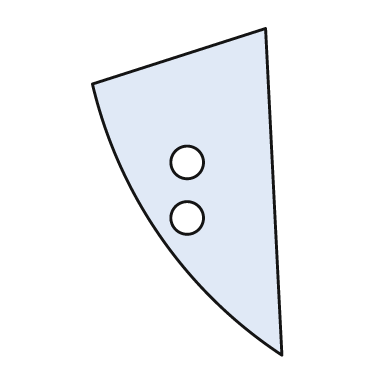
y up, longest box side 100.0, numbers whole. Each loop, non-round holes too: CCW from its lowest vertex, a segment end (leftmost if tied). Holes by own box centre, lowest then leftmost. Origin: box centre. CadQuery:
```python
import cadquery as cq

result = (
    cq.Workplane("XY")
    .moveTo(29.0, -50.0)
    .lineTo(24.0, 50.0)
    .lineTo(-29.0, 33.0)
    .threePointArc((-8.0, -14.0), (29.0, -50.0))
    .close()
    .moveTo(0.0, -8.0)
    .circle(5.0)
    .moveTo(0.0, 9.0)
    .circle(5.0)
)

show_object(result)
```